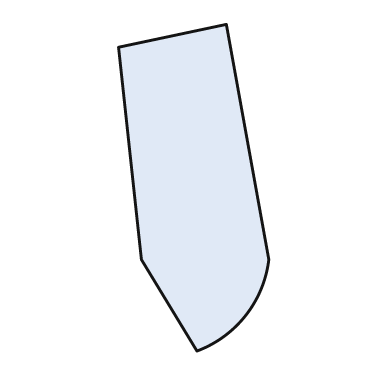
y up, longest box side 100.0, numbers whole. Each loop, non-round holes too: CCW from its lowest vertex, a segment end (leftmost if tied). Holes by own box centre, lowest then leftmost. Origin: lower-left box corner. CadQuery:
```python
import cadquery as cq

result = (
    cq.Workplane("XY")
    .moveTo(24.0, 0.0)
    .threePointArc((39.0, 11.0), (46.0, 28.0))
    .lineTo(33.0, 100.0)
    .lineTo(0.0, 93.0)
    .lineTo(7.0, 28.0)
    .close()
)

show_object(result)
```